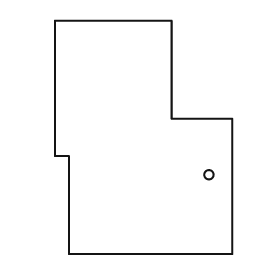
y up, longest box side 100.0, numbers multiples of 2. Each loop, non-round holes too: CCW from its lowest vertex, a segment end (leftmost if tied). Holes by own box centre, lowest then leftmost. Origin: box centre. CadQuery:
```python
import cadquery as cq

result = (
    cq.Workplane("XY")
    .moveTo(-32.0, -50.0)
    .lineTo(38.0, -50.0)
    .lineTo(38.0, 8.0)
    .lineTo(12.0, 8.0)
    .lineTo(12.0, 50.0)
    .lineTo(-38.0, 50.0)
    .lineTo(-38.0, -8.0)
    .lineTo(-32.0, -8.0)
    .close()
    .moveTo(28.0, -16.0)
    .circle(2.0)
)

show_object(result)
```